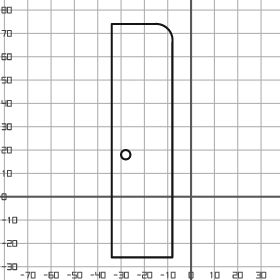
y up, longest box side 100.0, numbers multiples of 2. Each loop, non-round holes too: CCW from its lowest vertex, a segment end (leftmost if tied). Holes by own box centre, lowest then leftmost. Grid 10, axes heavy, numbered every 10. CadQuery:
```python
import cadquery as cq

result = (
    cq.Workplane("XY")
    .moveTo(-34.0, -26.0)
    .lineTo(-8.0, -26.0)
    .lineTo(-8.0, 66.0)
    .threePointArc((-10.0, 72.0), (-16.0, 74.0))
    .lineTo(-34.0, 74.0)
    .close()
    .moveTo(-28.0, 18.0)
    .circle(2.0)
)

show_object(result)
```